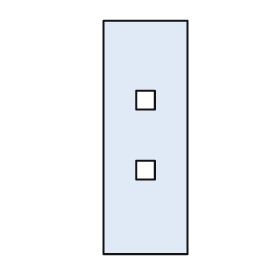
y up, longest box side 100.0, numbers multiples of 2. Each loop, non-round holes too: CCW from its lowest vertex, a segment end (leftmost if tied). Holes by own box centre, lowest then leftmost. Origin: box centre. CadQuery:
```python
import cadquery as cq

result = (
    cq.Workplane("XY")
    .moveTo(-18.0, -50.0)
    .lineTo(18.0, -50.0)
    .lineTo(18.0, 50.0)
    .lineTo(-18.0, 50.0)
    .close()
    .moveTo(-4.0, -18.0)
    .lineTo(4.0, -18.0)
    .lineTo(4.0, -10.0)
    .lineTo(-4.0, -10.0)
    .close()
    .moveTo(-4.0, 12.0)
    .lineTo(4.0, 12.0)
    .lineTo(4.0, 20.0)
    .lineTo(-4.0, 20.0)
    .close()
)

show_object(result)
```